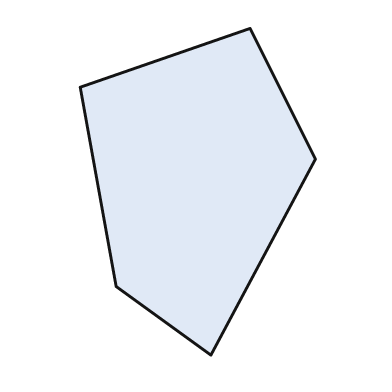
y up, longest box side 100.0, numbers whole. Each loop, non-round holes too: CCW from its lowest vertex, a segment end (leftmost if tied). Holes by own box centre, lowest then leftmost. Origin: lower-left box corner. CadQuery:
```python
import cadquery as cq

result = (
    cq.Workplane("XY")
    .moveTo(40.0, 0.0)
    .lineTo(72.0, 60.0)
    .lineTo(52.0, 100.0)
    .lineTo(0.0, 82.0)
    .lineTo(11.0, 21.0)
    .close()
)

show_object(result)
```